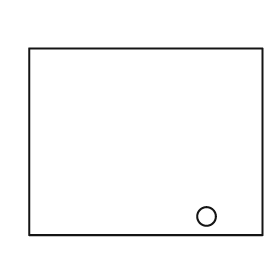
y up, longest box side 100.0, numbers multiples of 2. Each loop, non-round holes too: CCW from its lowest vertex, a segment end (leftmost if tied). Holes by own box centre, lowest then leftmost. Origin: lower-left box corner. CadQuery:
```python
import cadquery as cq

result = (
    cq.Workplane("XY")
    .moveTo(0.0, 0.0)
    .lineTo(100.0, 0.0)
    .lineTo(100.0, 80.0)
    .lineTo(0.0, 80.0)
    .close()
    .moveTo(76.0, 8.0)
    .circle(4.0)
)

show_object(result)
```